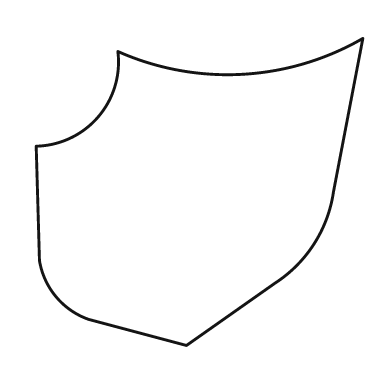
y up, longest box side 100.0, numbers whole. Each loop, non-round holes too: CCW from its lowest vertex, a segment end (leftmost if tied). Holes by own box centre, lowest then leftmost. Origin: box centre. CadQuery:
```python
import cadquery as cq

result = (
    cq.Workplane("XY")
    .moveTo(-4.0, -47.0)
    .lineTo(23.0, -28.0)
    .threePointArc((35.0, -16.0), (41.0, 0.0))
    .lineTo(50.0, 47.0)
    .threePointArc((13.0, 36.0), (-25.0, 43.0))
    .threePointArc((-31.0, 23.0), (-50.0, 14.0))
    .lineTo(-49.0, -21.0)
    .threePointArc((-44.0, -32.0), (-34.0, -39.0))
    .close()
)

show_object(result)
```